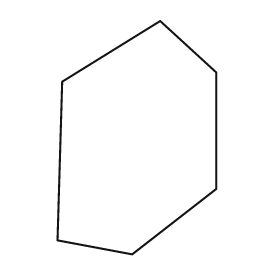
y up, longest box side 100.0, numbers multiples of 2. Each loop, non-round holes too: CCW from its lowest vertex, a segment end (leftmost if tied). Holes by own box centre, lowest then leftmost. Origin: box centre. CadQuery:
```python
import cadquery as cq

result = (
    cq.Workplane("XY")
    .moveTo(-2.0, -50.0)
    .lineTo(34.0, -22.0)
    .lineTo(34.0, 28.0)
    .lineTo(10.0, 50.0)
    .lineTo(-32.0, 24.0)
    .lineTo(-34.0, -44.0)
    .close()
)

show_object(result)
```